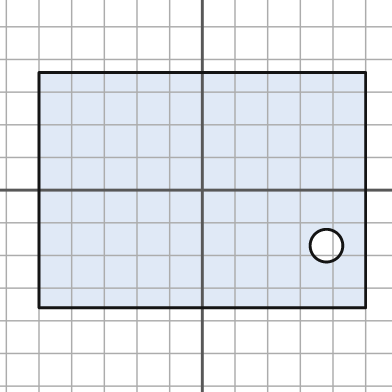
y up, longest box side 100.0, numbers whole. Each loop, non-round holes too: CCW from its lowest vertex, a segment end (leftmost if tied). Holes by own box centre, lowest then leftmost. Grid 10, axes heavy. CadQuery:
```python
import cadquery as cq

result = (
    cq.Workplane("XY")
    .moveTo(-50.0, -36.0)
    .lineTo(50.0, -36.0)
    .lineTo(50.0, 36.0)
    .lineTo(-50.0, 36.0)
    .close()
    .moveTo(38.0, -17.0)
    .circle(5.0)
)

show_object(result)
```